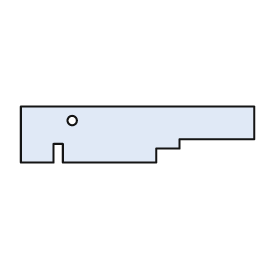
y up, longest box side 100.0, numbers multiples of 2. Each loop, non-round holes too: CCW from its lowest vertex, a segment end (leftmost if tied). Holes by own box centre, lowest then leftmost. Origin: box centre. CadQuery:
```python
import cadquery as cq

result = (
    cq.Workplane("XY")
    .moveTo(-50.0, -12.0)
    .lineTo(-36.0, -12.0)
    .lineTo(-36.0, -4.0)
    .lineTo(-32.0, -4.0)
    .lineTo(-32.0, -12.0)
    .lineTo(8.0, -12.0)
    .lineTo(8.0, -6.0)
    .lineTo(18.0, -6.0)
    .lineTo(18.0, -2.0)
    .lineTo(50.0, -2.0)
    .lineTo(50.0, 12.0)
    .lineTo(-50.0, 12.0)
    .close()
    .moveTo(-28.0, 6.0)
    .circle(2.0)
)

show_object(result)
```